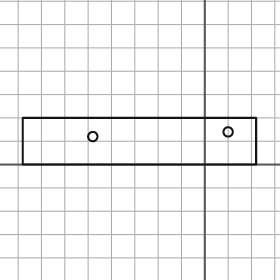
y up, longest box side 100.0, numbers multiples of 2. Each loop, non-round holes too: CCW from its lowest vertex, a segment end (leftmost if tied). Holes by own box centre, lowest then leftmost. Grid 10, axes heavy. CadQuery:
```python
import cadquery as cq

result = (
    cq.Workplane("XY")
    .moveTo(-78.0, 0.0)
    .lineTo(22.0, 0.0)
    .lineTo(22.0, 20.0)
    .lineTo(-78.0, 20.0)
    .close()
    .moveTo(-48.0, 12.0)
    .circle(2.0)
    .moveTo(10.0, 14.0)
    .circle(2.0)
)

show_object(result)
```